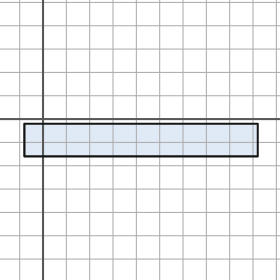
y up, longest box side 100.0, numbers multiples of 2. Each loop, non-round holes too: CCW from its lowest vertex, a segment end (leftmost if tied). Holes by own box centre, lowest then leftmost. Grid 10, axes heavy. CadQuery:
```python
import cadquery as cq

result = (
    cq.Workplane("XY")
    .moveTo(-8.0, -16.0)
    .lineTo(92.0, -16.0)
    .lineTo(92.0, -2.0)
    .lineTo(-8.0, -2.0)
    .close()
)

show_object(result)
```